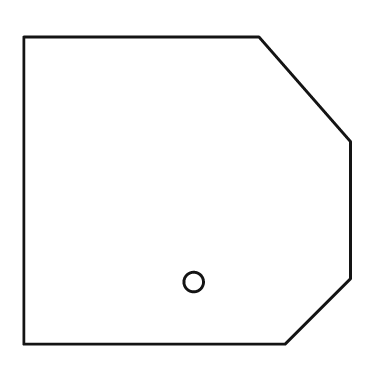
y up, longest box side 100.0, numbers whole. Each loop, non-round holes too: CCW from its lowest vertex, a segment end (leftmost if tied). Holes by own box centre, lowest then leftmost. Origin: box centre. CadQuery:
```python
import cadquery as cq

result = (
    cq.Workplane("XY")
    .moveTo(-50.0, -47.0)
    .lineTo(30.0, -47.0)
    .lineTo(50.0, -27.0)
    .lineTo(50.0, 15.0)
    .lineTo(22.0, 47.0)
    .lineTo(-50.0, 47.0)
    .close()
    .moveTo(2.0, -28.0)
    .circle(3.0)
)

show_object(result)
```